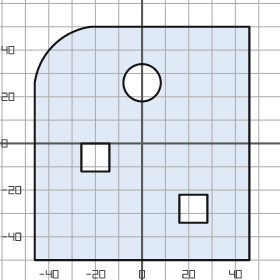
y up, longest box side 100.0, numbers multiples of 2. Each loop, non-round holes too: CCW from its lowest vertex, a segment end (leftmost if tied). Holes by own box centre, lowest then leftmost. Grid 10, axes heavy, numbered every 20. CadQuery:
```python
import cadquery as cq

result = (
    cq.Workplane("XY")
    .moveTo(-46.0, -50.0)
    .lineTo(46.0, -50.0)
    .lineTo(46.0, 50.0)
    .lineTo(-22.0, 50.0)
    .threePointArc((-38.0, 42.0), (-46.0, 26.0))
    .close()
    .moveTo(16.0, -34.0)
    .lineTo(28.0, -34.0)
    .lineTo(28.0, -22.0)
    .lineTo(16.0, -22.0)
    .close()
    .moveTo(-26.0, -12.0)
    .lineTo(-14.0, -12.0)
    .lineTo(-14.0, 0.0)
    .lineTo(-26.0, 0.0)
    .close()
    .moveTo(0.0, 26.0)
    .circle(8.0)
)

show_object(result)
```